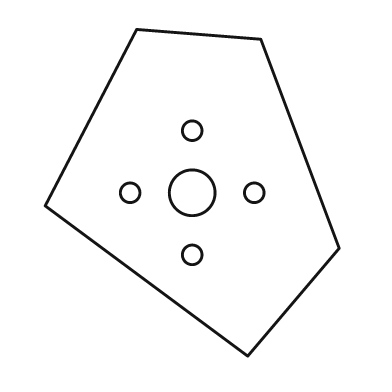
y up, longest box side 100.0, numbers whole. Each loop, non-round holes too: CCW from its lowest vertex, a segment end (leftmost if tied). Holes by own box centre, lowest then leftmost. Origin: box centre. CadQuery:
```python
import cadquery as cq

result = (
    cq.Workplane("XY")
    .moveTo(17.0, -50.0)
    .lineTo(45.0, -17.0)
    .lineTo(21.0, 47.0)
    .lineTo(-17.0, 50.0)
    .lineTo(-45.0, -4.0)
    .close()
    .moveTo(0.0, -19.0)
    .circle(3.0)
    .moveTo(-19.0, 0.0)
    .circle(3.0)
    .moveTo(0.0, 0.0)
    .circle(7.0)
    .moveTo(19.0, 0.0)
    .circle(3.0)
    .moveTo(0.0, 19.0)
    .circle(3.0)
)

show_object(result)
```